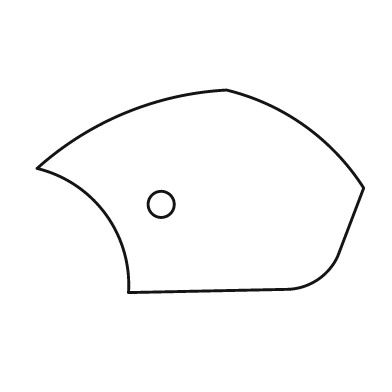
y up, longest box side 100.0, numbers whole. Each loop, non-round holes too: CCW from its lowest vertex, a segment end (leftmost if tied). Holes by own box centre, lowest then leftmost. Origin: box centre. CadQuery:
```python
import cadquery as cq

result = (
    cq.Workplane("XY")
    .moveTo(-22.0, -31.0)
    .lineTo(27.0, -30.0)
    .threePointArc((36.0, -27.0), (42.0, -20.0))
    .lineTo(50.0, 1.0)
    .threePointArc((32.0, 20.0), (8.0, 31.0))
    .threePointArc((-23.0, 24.0), (-50.0, 7.0))
    .threePointArc((-29.0, -7.0), (-22.0, -31.0))
    .close()
    .moveTo(-12.0, -4.0)
    .circle(4.0)
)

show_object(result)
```